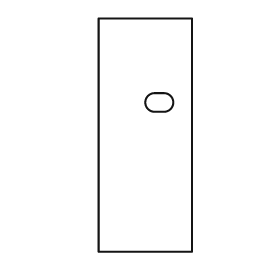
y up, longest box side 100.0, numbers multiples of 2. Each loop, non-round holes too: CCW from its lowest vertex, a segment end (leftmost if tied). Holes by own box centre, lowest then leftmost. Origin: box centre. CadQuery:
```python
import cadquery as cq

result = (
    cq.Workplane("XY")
    .moveTo(-20.0, -50.0)
    .lineTo(20.0, -50.0)
    .lineTo(20.0, 50.0)
    .lineTo(-20.0, 50.0)
    .close()
    .moveTo(4.0, 10.0)
    .lineTo(8.0, 10.0)
    .threePointArc((12.0, 14.0), (8.0, 18.0))
    .lineTo(4.0, 18.0)
    .threePointArc((0.0, 14.0), (4.0, 10.0))
    .close()
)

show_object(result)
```